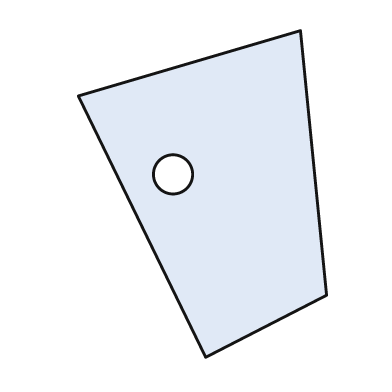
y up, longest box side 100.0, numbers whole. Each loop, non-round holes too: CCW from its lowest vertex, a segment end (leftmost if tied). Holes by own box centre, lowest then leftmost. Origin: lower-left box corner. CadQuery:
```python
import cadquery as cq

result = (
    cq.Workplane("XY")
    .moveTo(39.0, 0.0)
    .lineTo(76.0, 19.0)
    .lineTo(68.0, 100.0)
    .lineTo(0.0, 80.0)
    .close()
    .moveTo(29.0, 56.0)
    .circle(6.0)
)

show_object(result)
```